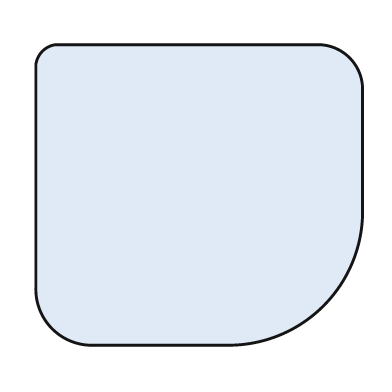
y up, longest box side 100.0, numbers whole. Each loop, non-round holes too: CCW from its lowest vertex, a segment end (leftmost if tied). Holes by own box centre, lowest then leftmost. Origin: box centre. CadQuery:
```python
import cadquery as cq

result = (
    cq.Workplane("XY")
    .moveTo(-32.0, -46.0)
    .lineTo(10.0, -46.0)
    .threePointArc((38.0, -34.0), (50.0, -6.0))
    .lineTo(50.0, 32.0)
    .threePointArc((46.0, 42.0), (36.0, 46.0))
    .lineTo(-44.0, 46.0)
    .threePointArc((-48.0, 44.0), (-50.0, 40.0))
    .lineTo(-50.0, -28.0)
    .threePointArc((-45.0, -41.0), (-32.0, -46.0))
    .close()
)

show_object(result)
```